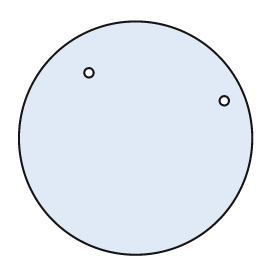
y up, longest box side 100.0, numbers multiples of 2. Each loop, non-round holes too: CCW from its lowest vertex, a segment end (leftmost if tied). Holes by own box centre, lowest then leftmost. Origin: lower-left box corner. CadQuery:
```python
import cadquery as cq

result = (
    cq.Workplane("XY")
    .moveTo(50.0, 50.0)
    .circle(50.0)
    .moveTo(88.0, 66.0)
    .circle(2.0)
    .moveTo(30.0, 78.0)
    .circle(2.0)
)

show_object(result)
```